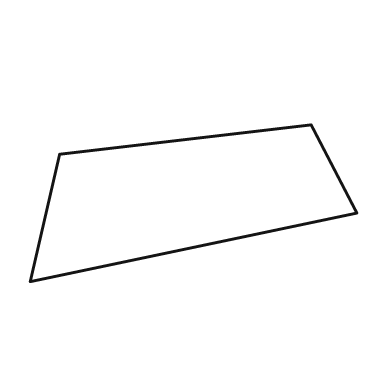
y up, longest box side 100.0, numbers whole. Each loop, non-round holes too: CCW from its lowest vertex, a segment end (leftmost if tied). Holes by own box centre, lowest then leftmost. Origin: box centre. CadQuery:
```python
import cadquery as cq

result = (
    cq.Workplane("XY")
    .moveTo(-50.0, -24.0)
    .lineTo(50.0, -3.0)
    .lineTo(36.0, 24.0)
    .lineTo(-41.0, 15.0)
    .close()
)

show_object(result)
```